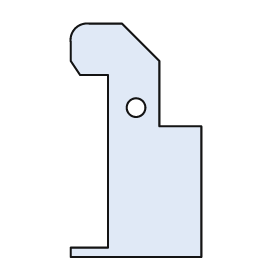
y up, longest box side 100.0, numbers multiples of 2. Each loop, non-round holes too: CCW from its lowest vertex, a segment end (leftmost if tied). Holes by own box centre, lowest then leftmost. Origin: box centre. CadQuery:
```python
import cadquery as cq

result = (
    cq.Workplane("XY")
    .moveTo(-28.0, -50.0)
    .lineTo(28.0, -50.0)
    .lineTo(28.0, 6.0)
    .lineTo(10.0, 6.0)
    .lineTo(10.0, 34.0)
    .lineTo(-6.0, 50.0)
    .lineTo(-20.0, 50.0)
    .threePointArc((-26.0, 48.0), (-28.0, 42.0))
    .lineTo(-28.0, 34.0)
    .lineTo(-24.0, 28.0)
    .lineTo(-12.0, 28.0)
    .lineTo(-12.0, -46.0)
    .lineTo(-28.0, -46.0)
    .close()
    .moveTo(0.0, 14.0)
    .circle(4.0)
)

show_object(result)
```